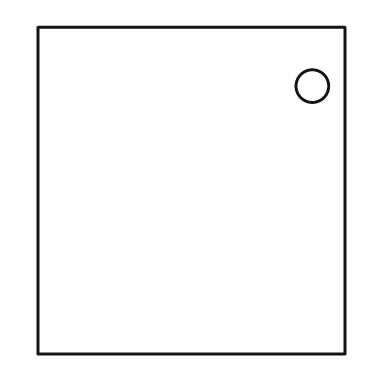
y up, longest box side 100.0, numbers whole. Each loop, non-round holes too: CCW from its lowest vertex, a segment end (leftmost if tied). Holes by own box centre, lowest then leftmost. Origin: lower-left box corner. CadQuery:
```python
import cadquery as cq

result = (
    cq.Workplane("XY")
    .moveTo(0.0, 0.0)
    .lineTo(94.0, 0.0)
    .lineTo(94.0, 100.0)
    .lineTo(0.0, 100.0)
    .close()
    .moveTo(84.0, 82.0)
    .circle(5.0)
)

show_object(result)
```